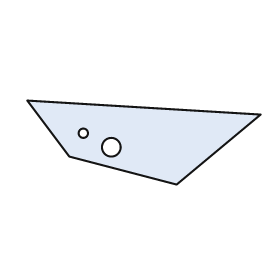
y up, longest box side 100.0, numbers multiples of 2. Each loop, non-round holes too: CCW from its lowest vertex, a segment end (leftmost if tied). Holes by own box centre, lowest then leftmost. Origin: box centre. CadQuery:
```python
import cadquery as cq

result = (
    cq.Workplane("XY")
    .moveTo(14.0, -18.0)
    .lineTo(50.0, 12.0)
    .lineTo(-50.0, 18.0)
    .lineTo(-32.0, -6.0)
    .close()
    .moveTo(-14.0, -2.0)
    .circle(4.0)
    .moveTo(-26.0, 4.0)
    .circle(2.0)
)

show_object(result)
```